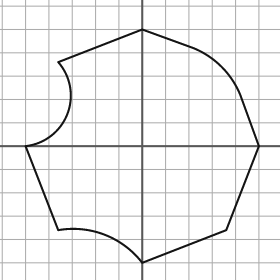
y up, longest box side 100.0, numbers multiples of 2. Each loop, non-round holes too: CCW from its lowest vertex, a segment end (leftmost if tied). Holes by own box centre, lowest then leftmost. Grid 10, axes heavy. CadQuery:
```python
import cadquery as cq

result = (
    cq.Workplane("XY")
    .moveTo(0.0, -50.0)
    .lineTo(36.0, -36.0)
    .lineTo(50.0, 0.0)
    .lineTo(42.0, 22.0)
    .threePointArc((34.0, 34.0), (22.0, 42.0))
    .lineTo(0.0, 50.0)
    .lineTo(-36.0, 36.0)
    .threePointArc((-32.0, 14.0), (-50.0, 0.0))
    .lineTo(-36.0, -36.0)
    .threePointArc((-16.0, -38.0), (0.0, -50.0))
    .close()
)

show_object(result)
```